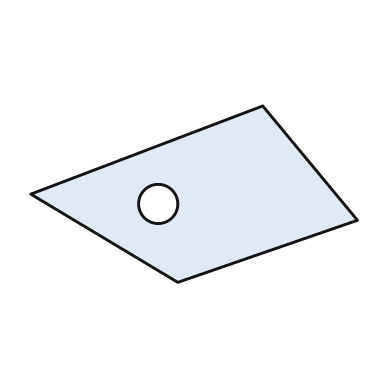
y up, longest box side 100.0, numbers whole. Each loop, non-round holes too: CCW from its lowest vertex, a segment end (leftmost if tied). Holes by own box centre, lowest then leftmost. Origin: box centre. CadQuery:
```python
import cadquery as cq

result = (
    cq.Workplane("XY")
    .moveTo(-5.0, -27.0)
    .lineTo(50.0, -8.0)
    .lineTo(21.0, 27.0)
    .lineTo(-50.0, 0.0)
    .close()
    .moveTo(-11.0, -3.0)
    .circle(6.0)
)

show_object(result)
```